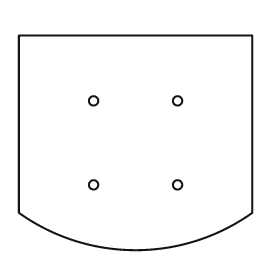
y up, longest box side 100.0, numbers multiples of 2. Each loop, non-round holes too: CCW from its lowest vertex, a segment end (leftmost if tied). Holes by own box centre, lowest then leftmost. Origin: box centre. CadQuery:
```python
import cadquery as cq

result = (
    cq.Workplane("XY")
    .moveTo(-50.0, -30.0)
    .threePointArc((0.0, -46.0), (50.0, -30.0))
    .lineTo(50.0, 46.0)
    .lineTo(-50.0, 46.0)
    .close()
    .moveTo(-18.0, -18.0)
    .circle(2.0)
    .moveTo(18.0, -18.0)
    .circle(2.0)
    .moveTo(-18.0, 18.0)
    .circle(2.0)
    .moveTo(18.0, 18.0)
    .circle(2.0)
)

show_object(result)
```